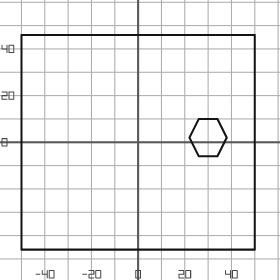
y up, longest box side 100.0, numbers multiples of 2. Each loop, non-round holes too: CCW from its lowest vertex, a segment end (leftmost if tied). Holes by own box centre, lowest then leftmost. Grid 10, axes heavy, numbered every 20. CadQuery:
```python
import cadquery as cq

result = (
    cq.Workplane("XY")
    .moveTo(-50.0, -46.0)
    .lineTo(50.0, -46.0)
    .lineTo(50.0, 46.0)
    .lineTo(-50.0, 46.0)
    .close()
    .moveTo(26.0, -6.0)
    .lineTo(34.0, -6.0)
    .lineTo(38.0, 2.0)
    .lineTo(34.0, 10.0)
    .lineTo(26.0, 10.0)
    .lineTo(22.0, 2.0)
    .close()
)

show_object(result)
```